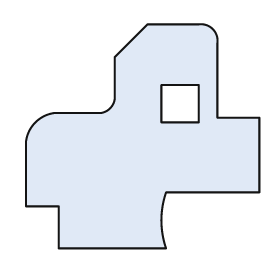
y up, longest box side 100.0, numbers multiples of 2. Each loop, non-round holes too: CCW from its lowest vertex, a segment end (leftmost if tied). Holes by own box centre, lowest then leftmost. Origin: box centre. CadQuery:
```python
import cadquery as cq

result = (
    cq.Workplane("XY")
    .moveTo(-36.0, -48.0)
    .lineTo(10.0, -48.0)
    .threePointArc((8.0, -36.0), (10.0, -24.0))
    .lineTo(50.0, -24.0)
    .lineTo(50.0, 8.0)
    .lineTo(32.0, 8.0)
    .lineTo(32.0, 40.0)
    .threePointArc((30.0, 46.0), (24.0, 48.0))
    .lineTo(2.0, 48.0)
    .lineTo(-12.0, 34.0)
    .lineTo(-12.0, 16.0)
    .threePointArc((-14.0, 12.0), (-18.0, 10.0))
    .lineTo(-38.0, 10.0)
    .threePointArc((-46.0, 6.0), (-50.0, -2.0))
    .lineTo(-50.0, -30.0)
    .lineTo(-36.0, -30.0)
    .close()
    .moveTo(8.0, 6.0)
    .lineTo(24.0, 6.0)
    .lineTo(24.0, 22.0)
    .lineTo(8.0, 22.0)
    .close()
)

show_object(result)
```